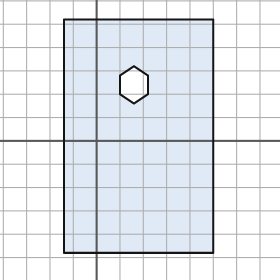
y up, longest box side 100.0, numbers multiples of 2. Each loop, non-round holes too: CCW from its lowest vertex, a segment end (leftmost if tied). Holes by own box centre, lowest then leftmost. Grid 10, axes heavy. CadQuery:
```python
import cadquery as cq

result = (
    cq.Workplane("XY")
    .moveTo(-14.0, -48.0)
    .lineTo(50.0, -48.0)
    .lineTo(50.0, 52.0)
    .lineTo(-14.0, 52.0)
    .close()
    .moveTo(16.0, 16.0)
    .lineTo(22.0, 20.0)
    .lineTo(22.0, 28.0)
    .lineTo(16.0, 32.0)
    .lineTo(10.0, 28.0)
    .lineTo(10.0, 20.0)
    .close()
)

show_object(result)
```